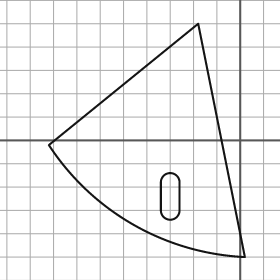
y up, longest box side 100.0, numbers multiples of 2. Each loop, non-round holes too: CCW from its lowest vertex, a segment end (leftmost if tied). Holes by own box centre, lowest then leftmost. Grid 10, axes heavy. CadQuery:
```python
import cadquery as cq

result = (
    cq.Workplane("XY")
    .moveTo(2.0, -50.0)
    .lineTo(-18.0, 50.0)
    .lineTo(-82.0, -2.0)
    .threePointArc((-46.0, -36.0), (2.0, -50.0))
    .close()
    .moveTo(-34.0, -30.0)
    .threePointArc((-30.0, -34.0), (-26.0, -30.0))
    .lineTo(-26.0, -18.0)
    .threePointArc((-30.0, -14.0), (-34.0, -18.0))
    .close()
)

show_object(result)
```